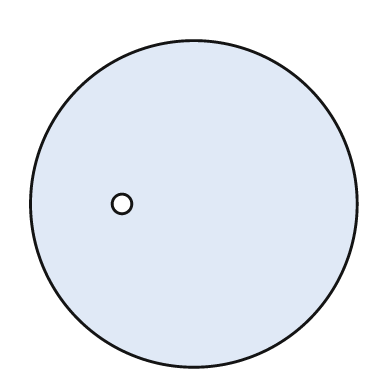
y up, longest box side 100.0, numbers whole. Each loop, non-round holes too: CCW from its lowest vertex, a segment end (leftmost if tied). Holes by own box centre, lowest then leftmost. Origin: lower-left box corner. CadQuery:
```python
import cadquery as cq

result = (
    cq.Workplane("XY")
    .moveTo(50.0, 50.0)
    .circle(50.0)
    .moveTo(28.0, 50.0)
    .circle(3.0)
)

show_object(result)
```